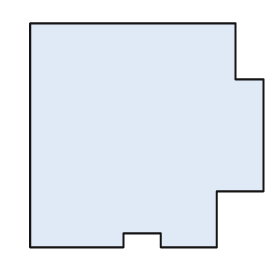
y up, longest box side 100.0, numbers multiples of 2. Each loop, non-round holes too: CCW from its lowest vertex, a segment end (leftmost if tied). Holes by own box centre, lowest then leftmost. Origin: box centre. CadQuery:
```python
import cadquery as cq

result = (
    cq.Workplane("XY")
    .moveTo(-50.0, -48.0)
    .lineTo(-10.0, -48.0)
    .lineTo(-10.0, -42.0)
    .lineTo(6.0, -42.0)
    .lineTo(6.0, -48.0)
    .lineTo(30.0, -48.0)
    .lineTo(30.0, -24.0)
    .lineTo(50.0, -24.0)
    .lineTo(50.0, 24.0)
    .lineTo(38.0, 24.0)
    .lineTo(38.0, 48.0)
    .lineTo(-50.0, 48.0)
    .close()
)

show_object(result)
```